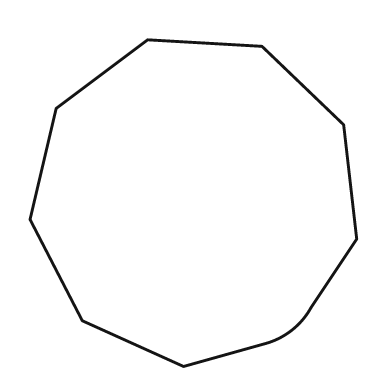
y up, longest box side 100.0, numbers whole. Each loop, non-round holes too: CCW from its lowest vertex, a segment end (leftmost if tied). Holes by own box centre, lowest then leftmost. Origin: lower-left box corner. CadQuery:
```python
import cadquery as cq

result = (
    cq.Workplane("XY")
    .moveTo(47.0, 0.0)
    .lineTo(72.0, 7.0)
    .threePointArc((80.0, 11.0), (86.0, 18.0))
    .lineTo(100.0, 39.0)
    .lineTo(96.0, 74.0)
    .lineTo(71.0, 98.0)
    .lineTo(36.0, 100.0)
    .lineTo(8.0, 79.0)
    .lineTo(0.0, 45.0)
    .lineTo(16.0, 14.0)
    .close()
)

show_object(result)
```